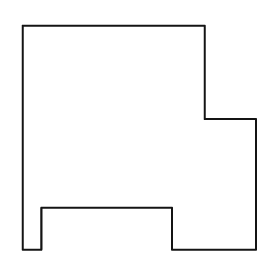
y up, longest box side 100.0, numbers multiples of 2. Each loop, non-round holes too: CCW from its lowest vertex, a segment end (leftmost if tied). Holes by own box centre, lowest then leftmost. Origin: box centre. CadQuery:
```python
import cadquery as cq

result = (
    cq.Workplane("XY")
    .moveTo(-50.0, -48.0)
    .lineTo(-42.0, -48.0)
    .lineTo(-42.0, -30.0)
    .lineTo(14.0, -30.0)
    .lineTo(14.0, -48.0)
    .lineTo(50.0, -48.0)
    .lineTo(50.0, 8.0)
    .lineTo(28.0, 8.0)
    .lineTo(28.0, 48.0)
    .lineTo(-50.0, 48.0)
    .close()
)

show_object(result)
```